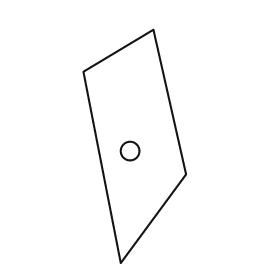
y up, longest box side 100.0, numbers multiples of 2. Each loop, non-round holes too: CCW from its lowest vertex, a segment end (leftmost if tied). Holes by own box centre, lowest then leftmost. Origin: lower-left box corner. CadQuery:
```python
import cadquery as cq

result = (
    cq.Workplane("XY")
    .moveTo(16.0, 0.0)
    .lineTo(44.0, 38.0)
    .lineTo(30.0, 100.0)
    .lineTo(0.0, 82.0)
    .close()
    .moveTo(20.0, 48.0)
    .circle(4.0)
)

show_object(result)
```